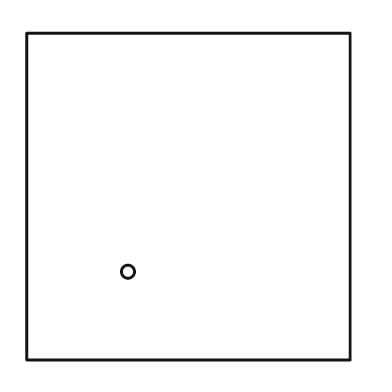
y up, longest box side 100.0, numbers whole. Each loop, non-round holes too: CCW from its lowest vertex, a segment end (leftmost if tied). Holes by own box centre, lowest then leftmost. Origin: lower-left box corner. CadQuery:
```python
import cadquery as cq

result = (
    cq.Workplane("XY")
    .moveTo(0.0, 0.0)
    .lineTo(99.0, 0.0)
    .lineTo(99.0, 100.0)
    .lineTo(0.0, 100.0)
    .close()
    .moveTo(31.0, 27.0)
    .circle(2.0)
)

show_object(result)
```